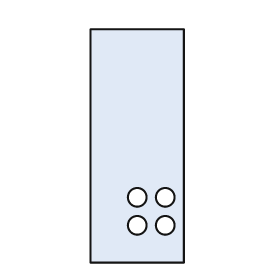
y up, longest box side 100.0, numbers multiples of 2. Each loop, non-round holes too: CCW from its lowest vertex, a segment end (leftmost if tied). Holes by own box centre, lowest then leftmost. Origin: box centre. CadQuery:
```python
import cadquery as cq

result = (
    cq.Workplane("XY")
    .moveTo(-20.0, -50.0)
    .lineTo(20.0, -50.0)
    .lineTo(20.0, 50.0)
    .lineTo(-20.0, 50.0)
    .close()
    .moveTo(0.0, -34.0)
    .circle(4.0)
    .moveTo(12.0, -34.0)
    .circle(4.0)
    .moveTo(0.0, -22.0)
    .circle(4.0)
    .moveTo(12.0, -22.0)
    .circle(4.0)
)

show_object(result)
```